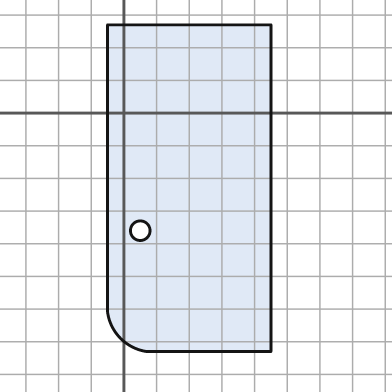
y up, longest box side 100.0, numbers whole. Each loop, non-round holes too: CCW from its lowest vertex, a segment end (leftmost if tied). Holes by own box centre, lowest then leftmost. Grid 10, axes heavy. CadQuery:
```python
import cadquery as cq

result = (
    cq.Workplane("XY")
    .moveTo(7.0, -73.0)
    .lineTo(45.0, -73.0)
    .lineTo(45.0, 27.0)
    .lineTo(-5.0, 27.0)
    .lineTo(-5.0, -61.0)
    .threePointArc((-1.0, -69.0), (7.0, -73.0))
    .close()
    .moveTo(5.0, -36.0)
    .circle(3.0)
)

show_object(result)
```